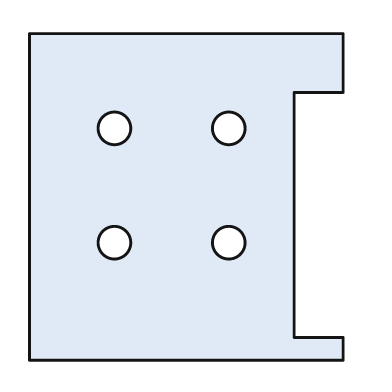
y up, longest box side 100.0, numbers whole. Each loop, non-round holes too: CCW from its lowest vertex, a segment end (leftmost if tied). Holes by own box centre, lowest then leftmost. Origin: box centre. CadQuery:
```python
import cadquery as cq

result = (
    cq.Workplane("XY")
    .moveTo(-48.0, -50.0)
    .lineTo(48.0, -50.0)
    .lineTo(48.0, -43.0)
    .lineTo(33.0, -43.0)
    .lineTo(33.0, 32.0)
    .lineTo(48.0, 32.0)
    .lineTo(48.0, 50.0)
    .lineTo(-48.0, 50.0)
    .close()
    .moveTo(-22.0, -14.0)
    .circle(5.0)
    .moveTo(13.0, -14.0)
    .circle(5.0)
    .moveTo(-22.0, 21.0)
    .circle(5.0)
    .moveTo(13.0, 21.0)
    .circle(5.0)
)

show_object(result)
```